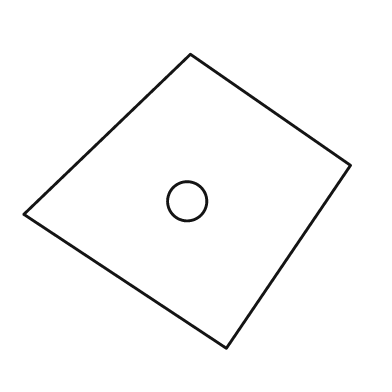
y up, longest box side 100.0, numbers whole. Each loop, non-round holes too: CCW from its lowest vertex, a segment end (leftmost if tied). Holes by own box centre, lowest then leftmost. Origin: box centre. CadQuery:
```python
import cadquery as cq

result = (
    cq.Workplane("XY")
    .moveTo(12.0, -45.0)
    .lineTo(50.0, 11.0)
    .lineTo(1.0, 45.0)
    .lineTo(-50.0, -4.0)
    .close()
    .moveTo(0.0, 0.0)
    .circle(6.0)
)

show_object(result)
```